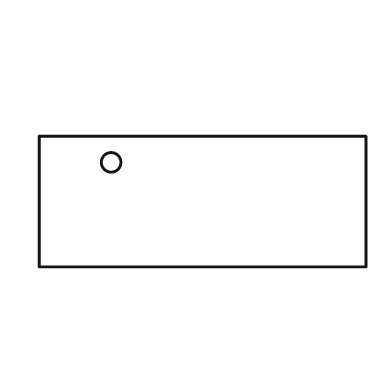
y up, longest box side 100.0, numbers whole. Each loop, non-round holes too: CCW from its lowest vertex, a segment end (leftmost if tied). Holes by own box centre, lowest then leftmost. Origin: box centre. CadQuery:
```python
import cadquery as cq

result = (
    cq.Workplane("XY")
    .moveTo(-50.0, -20.0)
    .lineTo(50.0, -20.0)
    .lineTo(50.0, 20.0)
    .lineTo(-50.0, 20.0)
    .close()
    .moveTo(-28.0, 12.0)
    .circle(3.0)
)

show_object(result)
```